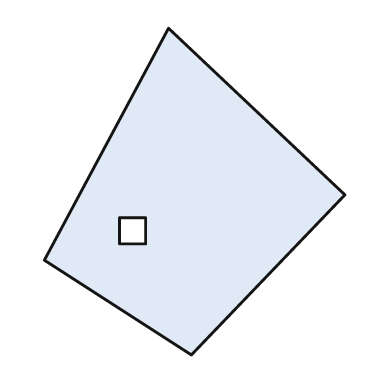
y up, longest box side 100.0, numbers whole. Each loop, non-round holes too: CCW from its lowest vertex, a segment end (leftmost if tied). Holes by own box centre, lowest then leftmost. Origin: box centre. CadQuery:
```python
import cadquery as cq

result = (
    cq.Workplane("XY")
    .moveTo(-1.0, -50.0)
    .lineTo(46.0, -1.0)
    .lineTo(-8.0, 50.0)
    .lineTo(-46.0, -21.0)
    .close()
    .moveTo(-23.0, -16.0)
    .lineTo(-15.0, -16.0)
    .lineTo(-15.0, -8.0)
    .lineTo(-23.0, -8.0)
    .close()
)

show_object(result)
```